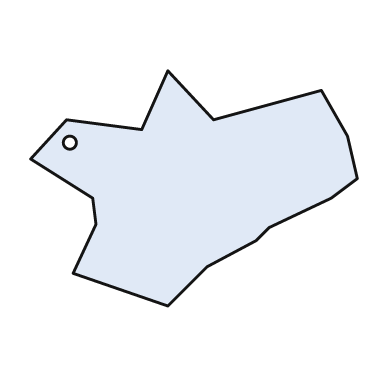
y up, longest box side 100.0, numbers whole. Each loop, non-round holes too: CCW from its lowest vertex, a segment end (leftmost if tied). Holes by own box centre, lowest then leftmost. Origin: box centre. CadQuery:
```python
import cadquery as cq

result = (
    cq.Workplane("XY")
    .moveTo(-8.0, -36.0)
    .lineTo(4.0, -24.0)
    .lineTo(19.0, -16.0)
    .lineTo(23.0, -12.0)
    .lineTo(42.0, -3.0)
    .lineTo(50.0, 3.0)
    .lineTo(47.0, 16.0)
    .lineTo(39.0, 30.0)
    .lineTo(6.0, 21.0)
    .lineTo(-8.0, 36.0)
    .lineTo(-16.0, 18.0)
    .lineTo(-39.0, 21.0)
    .lineTo(-50.0, 9.0)
    .lineTo(-31.0, -3.0)
    .lineTo(-30.0, -11.0)
    .lineTo(-37.0, -26.0)
    .close()
    .moveTo(-38.0, 14.0)
    .circle(2.0)
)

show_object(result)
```